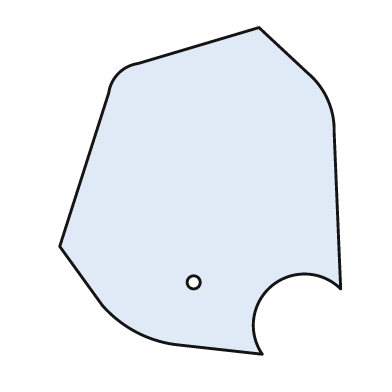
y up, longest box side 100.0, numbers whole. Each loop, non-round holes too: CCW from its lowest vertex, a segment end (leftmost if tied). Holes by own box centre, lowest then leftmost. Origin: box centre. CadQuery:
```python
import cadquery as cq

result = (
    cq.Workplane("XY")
    .moveTo(19.0, -50.0)
    .threePointArc((22.0, -29.0), (43.0, -30.0))
    .lineTo(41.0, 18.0)
    .threePointArc((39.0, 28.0), (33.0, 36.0))
    .lineTo(18.0, 50.0)
    .lineTo(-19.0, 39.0)
    .threePointArc((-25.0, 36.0), (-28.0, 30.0))
    .lineTo(-43.0, -17.0)
    .lineTo(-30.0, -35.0)
    .threePointArc((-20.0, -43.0), (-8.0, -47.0))
    .close()
    .moveTo(-2.0, -28.0)
    .circle(2.0)
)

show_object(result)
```